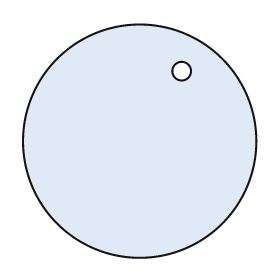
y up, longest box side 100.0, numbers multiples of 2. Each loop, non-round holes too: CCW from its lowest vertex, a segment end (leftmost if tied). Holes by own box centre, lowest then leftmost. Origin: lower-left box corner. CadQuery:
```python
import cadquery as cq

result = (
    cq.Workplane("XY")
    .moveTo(50.0, 50.0)
    .circle(50.0)
    .moveTo(68.0, 80.0)
    .circle(4.0)
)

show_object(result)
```